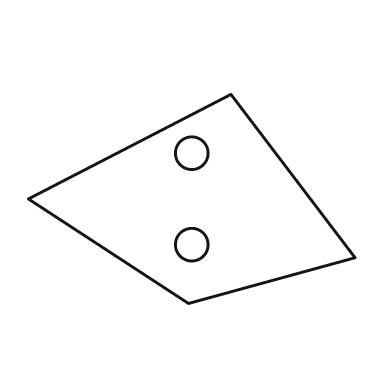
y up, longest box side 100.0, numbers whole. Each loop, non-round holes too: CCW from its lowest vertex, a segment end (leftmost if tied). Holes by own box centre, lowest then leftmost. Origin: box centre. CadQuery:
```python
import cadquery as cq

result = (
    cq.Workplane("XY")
    .moveTo(-1.0, -32.0)
    .lineTo(50.0, -18.0)
    .lineTo(12.0, 32.0)
    .lineTo(-50.0, 0.0)
    .close()
    .moveTo(0.0, -14.0)
    .circle(5.0)
    .moveTo(0.0, 14.0)
    .circle(5.0)
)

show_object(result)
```